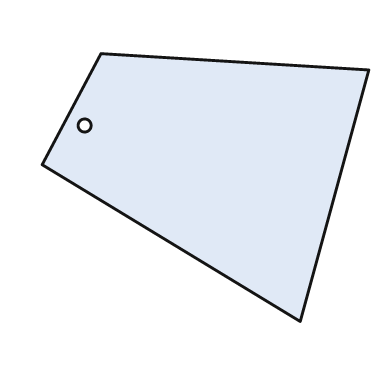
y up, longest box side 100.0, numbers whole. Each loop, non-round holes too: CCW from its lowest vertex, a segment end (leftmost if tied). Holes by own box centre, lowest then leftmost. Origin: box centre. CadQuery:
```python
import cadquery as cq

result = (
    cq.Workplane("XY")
    .moveTo(29.0, -41.0)
    .lineTo(50.0, 36.0)
    .lineTo(-32.0, 41.0)
    .lineTo(-50.0, 7.0)
    .close()
    .moveTo(-37.0, 19.0)
    .circle(2.0)
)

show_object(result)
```